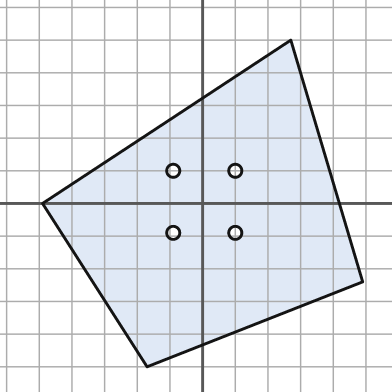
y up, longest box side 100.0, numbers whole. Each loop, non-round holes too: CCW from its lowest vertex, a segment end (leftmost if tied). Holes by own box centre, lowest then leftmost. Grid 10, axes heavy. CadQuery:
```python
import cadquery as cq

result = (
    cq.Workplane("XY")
    .moveTo(-17.0, -50.0)
    .lineTo(49.0, -24.0)
    .lineTo(27.0, 50.0)
    .lineTo(-49.0, 0.0)
    .close()
    .moveTo(-9.0, -9.0)
    .circle(2.0)
    .moveTo(10.0, -9.0)
    .circle(2.0)
    .moveTo(-9.0, 10.0)
    .circle(2.0)
    .moveTo(10.0, 10.0)
    .circle(2.0)
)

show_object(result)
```